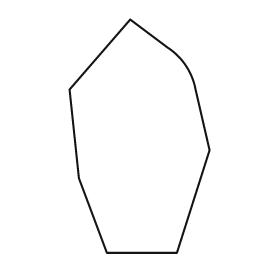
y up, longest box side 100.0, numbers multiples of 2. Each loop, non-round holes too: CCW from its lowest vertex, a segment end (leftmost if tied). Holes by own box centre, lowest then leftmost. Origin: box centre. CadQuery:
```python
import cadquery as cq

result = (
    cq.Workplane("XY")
    .moveTo(-14.0, -50.0)
    .lineTo(16.0, -50.0)
    .lineTo(30.0, -6.0)
    .lineTo(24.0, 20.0)
    .threePointArc((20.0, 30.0), (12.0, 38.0))
    .lineTo(-4.0, 50.0)
    .lineTo(-30.0, 20.0)
    .lineTo(-26.0, -18.0)
    .close()
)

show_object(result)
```